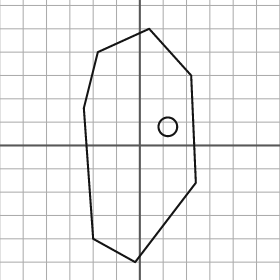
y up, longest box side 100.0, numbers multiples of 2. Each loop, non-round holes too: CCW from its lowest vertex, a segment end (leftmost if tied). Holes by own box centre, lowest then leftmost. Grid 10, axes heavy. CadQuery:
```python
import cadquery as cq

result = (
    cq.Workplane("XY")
    .moveTo(-2.0, -50.0)
    .lineTo(24.0, -16.0)
    .lineTo(22.0, 30.0)
    .lineTo(4.0, 50.0)
    .lineTo(-18.0, 40.0)
    .lineTo(-24.0, 16.0)
    .lineTo(-20.0, -40.0)
    .close()
    .moveTo(12.0, 8.0)
    .circle(4.0)
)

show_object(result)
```